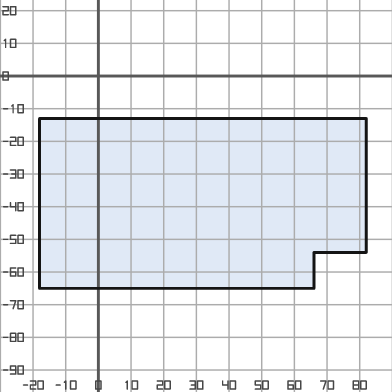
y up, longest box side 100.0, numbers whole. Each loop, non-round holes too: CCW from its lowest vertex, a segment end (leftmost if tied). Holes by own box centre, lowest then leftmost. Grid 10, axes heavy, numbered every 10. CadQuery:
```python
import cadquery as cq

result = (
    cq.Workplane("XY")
    .moveTo(-18.0, -65.0)
    .lineTo(66.0, -65.0)
    .lineTo(66.0, -54.0)
    .lineTo(82.0, -54.0)
    .lineTo(82.0, -13.0)
    .lineTo(-18.0, -13.0)
    .close()
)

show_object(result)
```